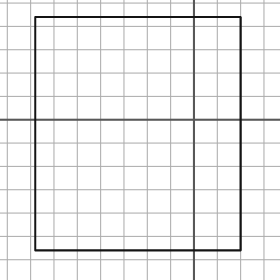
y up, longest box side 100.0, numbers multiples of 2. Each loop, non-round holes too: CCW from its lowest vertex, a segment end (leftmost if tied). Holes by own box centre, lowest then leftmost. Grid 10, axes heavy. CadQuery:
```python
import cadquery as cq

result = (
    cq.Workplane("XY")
    .moveTo(-68.0, -56.0)
    .lineTo(20.0, -56.0)
    .lineTo(20.0, 44.0)
    .lineTo(-68.0, 44.0)
    .close()
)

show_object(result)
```